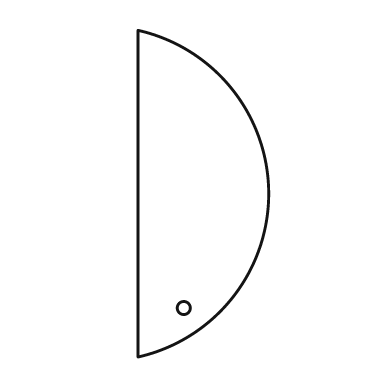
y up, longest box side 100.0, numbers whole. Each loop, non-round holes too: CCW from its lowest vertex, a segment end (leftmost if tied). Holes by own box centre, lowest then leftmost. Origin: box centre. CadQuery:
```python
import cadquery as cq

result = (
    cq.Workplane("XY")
    .moveTo(-20.0, -50.0)
    .threePointArc((20.0, 0.0), (-20.0, 50.0))
    .close()
    .moveTo(-6.0, -35.0)
    .circle(2.0)
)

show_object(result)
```